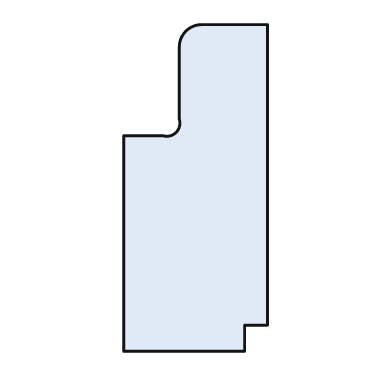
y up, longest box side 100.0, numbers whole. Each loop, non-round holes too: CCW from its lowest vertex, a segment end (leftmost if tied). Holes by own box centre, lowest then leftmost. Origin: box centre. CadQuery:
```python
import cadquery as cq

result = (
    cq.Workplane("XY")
    .moveTo(-22.0, -50.0)
    .lineTo(15.0, -50.0)
    .lineTo(15.0, -42.0)
    .lineTo(22.0, -42.0)
    .lineTo(22.0, 50.0)
    .lineTo(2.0, 50.0)
    .threePointArc((-3.0, 48.0), (-5.0, 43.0))
    .lineTo(-5.0, 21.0)
    .threePointArc((-6.0, 17.0), (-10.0, 16.0))
    .lineTo(-22.0, 16.0)
    .close()
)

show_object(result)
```